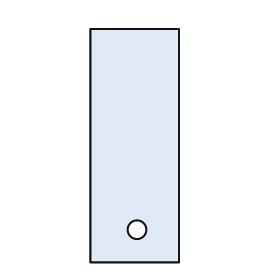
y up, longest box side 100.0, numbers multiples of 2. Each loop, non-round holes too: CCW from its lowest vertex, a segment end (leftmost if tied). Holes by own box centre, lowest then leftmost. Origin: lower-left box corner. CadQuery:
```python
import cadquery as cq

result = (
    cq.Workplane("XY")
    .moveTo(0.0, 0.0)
    .lineTo(38.0, 0.0)
    .lineTo(38.0, 100.0)
    .lineTo(0.0, 100.0)
    .close()
    .moveTo(20.0, 14.0)
    .circle(4.0)
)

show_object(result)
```